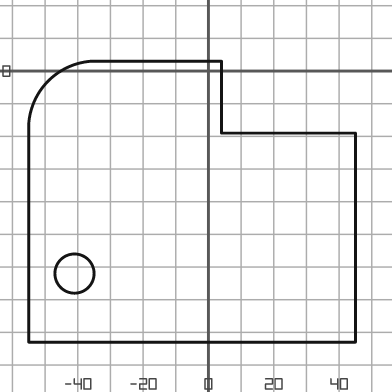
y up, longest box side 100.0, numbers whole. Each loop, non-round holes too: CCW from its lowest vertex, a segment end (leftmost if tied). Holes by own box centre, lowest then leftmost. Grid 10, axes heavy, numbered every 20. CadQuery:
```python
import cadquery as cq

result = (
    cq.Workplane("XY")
    .moveTo(-55.0, -83.0)
    .lineTo(45.0, -83.0)
    .lineTo(45.0, -19.0)
    .lineTo(4.0, -19.0)
    .lineTo(4.0, 3.0)
    .lineTo(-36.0, 3.0)
    .threePointArc((-49.0, -3.0), (-55.0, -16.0))
    .close()
    .moveTo(-41.0, -62.0)
    .circle(6.0)
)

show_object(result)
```